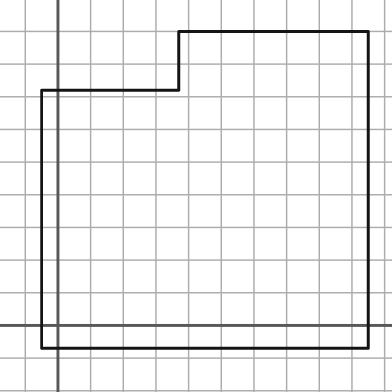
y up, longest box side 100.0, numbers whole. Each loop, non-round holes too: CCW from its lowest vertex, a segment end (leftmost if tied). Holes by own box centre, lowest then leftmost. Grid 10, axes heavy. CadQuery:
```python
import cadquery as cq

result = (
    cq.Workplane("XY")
    .moveTo(-5.0, -7.0)
    .lineTo(95.0, -7.0)
    .lineTo(95.0, 90.0)
    .lineTo(37.0, 90.0)
    .lineTo(37.0, 72.0)
    .lineTo(-5.0, 72.0)
    .close()
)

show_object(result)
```